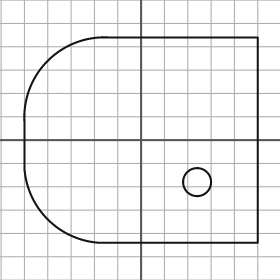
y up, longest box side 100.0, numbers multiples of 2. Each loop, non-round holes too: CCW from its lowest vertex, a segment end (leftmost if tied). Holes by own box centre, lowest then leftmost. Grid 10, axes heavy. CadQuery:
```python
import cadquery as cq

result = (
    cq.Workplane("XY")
    .moveTo(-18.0, -44.0)
    .lineTo(50.0, -44.0)
    .lineTo(50.0, 44.0)
    .lineTo(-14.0, 44.0)
    .threePointArc((-40.0, 34.0), (-50.0, 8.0))
    .lineTo(-50.0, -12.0)
    .threePointArc((-40.0, -34.0), (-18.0, -44.0))
    .close()
    .moveTo(24.0, -18.0)
    .circle(6.0)
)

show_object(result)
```